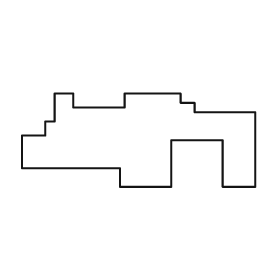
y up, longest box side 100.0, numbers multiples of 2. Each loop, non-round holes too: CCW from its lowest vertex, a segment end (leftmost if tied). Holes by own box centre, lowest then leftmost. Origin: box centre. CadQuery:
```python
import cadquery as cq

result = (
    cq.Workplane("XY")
    .moveTo(-8.0, -20.0)
    .lineTo(14.0, -20.0)
    .lineTo(14.0, 0.0)
    .lineTo(36.0, 0.0)
    .lineTo(36.0, -20.0)
    .lineTo(50.0, -20.0)
    .lineTo(50.0, 12.0)
    .lineTo(24.0, 12.0)
    .lineTo(24.0, 16.0)
    .lineTo(18.0, 16.0)
    .lineTo(18.0, 20.0)
    .lineTo(-6.0, 20.0)
    .lineTo(-6.0, 14.0)
    .lineTo(-28.0, 14.0)
    .lineTo(-28.0, 20.0)
    .lineTo(-36.0, 20.0)
    .lineTo(-36.0, 8.0)
    .lineTo(-40.0, 8.0)
    .lineTo(-40.0, 2.0)
    .lineTo(-50.0, 2.0)
    .lineTo(-50.0, -12.0)
    .lineTo(-8.0, -12.0)
    .close()
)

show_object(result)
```